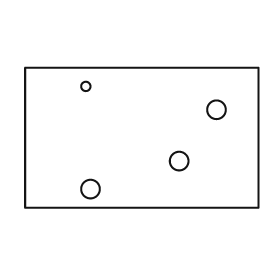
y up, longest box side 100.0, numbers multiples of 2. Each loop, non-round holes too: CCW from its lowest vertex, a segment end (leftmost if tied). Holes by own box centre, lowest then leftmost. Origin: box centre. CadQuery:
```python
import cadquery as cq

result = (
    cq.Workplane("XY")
    .moveTo(-50.0, -30.0)
    .lineTo(50.0, -30.0)
    .lineTo(50.0, 30.0)
    .lineTo(-50.0, 30.0)
    .close()
    .moveTo(-22.0, -22.0)
    .circle(4.0)
    .moveTo(16.0, -10.0)
    .circle(4.0)
    .moveTo(32.0, 12.0)
    .circle(4.0)
    .moveTo(-24.0, 22.0)
    .circle(2.0)
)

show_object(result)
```